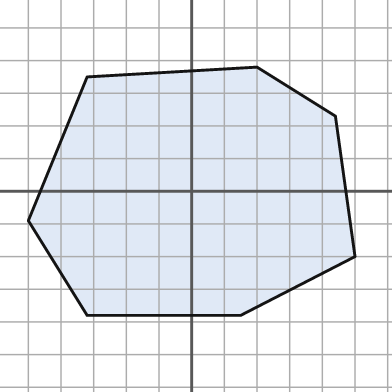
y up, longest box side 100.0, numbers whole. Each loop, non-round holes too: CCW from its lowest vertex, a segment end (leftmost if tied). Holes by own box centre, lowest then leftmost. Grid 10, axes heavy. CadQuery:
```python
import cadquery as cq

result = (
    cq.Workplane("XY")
    .moveTo(-32.0, -38.0)
    .lineTo(15.0, -38.0)
    .lineTo(50.0, -20.0)
    .lineTo(44.0, 23.0)
    .lineTo(20.0, 38.0)
    .lineTo(-32.0, 35.0)
    .lineTo(-50.0, -9.0)
    .close()
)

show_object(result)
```